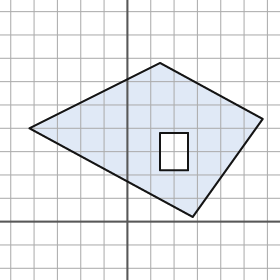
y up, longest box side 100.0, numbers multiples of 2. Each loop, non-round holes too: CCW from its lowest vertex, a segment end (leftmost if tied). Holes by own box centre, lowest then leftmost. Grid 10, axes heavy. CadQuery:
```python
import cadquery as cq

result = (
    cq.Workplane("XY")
    .moveTo(28.0, 2.0)
    .lineTo(58.0, 44.0)
    .lineTo(14.0, 68.0)
    .lineTo(-42.0, 40.0)
    .close()
    .moveTo(14.0, 22.0)
    .lineTo(26.0, 22.0)
    .lineTo(26.0, 38.0)
    .lineTo(14.0, 38.0)
    .close()
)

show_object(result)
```